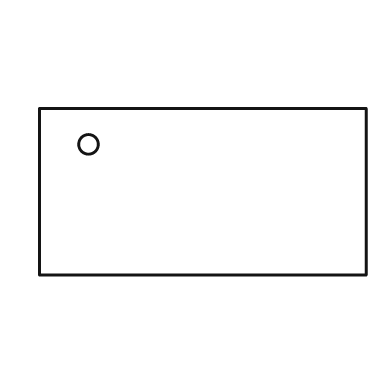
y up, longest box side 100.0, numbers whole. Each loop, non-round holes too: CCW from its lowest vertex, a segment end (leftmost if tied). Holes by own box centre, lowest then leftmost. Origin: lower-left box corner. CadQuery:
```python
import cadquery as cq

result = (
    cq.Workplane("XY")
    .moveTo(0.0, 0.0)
    .lineTo(100.0, 0.0)
    .lineTo(100.0, 51.0)
    .lineTo(0.0, 51.0)
    .close()
    .moveTo(15.0, 40.0)
    .circle(3.0)
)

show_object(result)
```